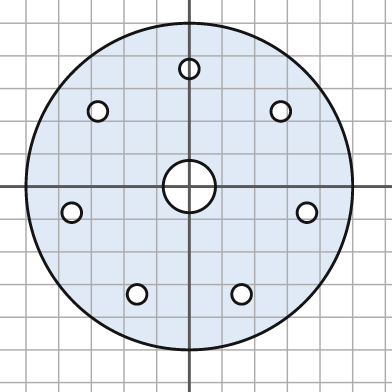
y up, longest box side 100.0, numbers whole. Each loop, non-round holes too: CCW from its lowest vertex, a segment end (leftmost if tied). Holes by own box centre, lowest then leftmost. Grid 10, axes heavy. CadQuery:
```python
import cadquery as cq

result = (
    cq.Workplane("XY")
    .moveTo(0.0, 0.0)
    .circle(50.0)
    .moveTo(-16.0, -33.0)
    .circle(3.0)
    .moveTo(16.0, -33.0)
    .circle(3.0)
    .moveTo(-36.0, -8.0)
    .circle(3.0)
    .moveTo(36.0, -8.0)
    .circle(3.0)
    .moveTo(0.0, 0.0)
    .circle(8.0)
    .moveTo(-28.0, 23.0)
    .circle(3.0)
    .moveTo(28.0, 23.0)
    .circle(3.0)
    .moveTo(0.0, 36.0)
    .circle(3.0)
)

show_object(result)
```